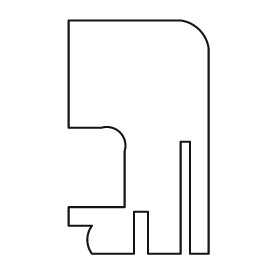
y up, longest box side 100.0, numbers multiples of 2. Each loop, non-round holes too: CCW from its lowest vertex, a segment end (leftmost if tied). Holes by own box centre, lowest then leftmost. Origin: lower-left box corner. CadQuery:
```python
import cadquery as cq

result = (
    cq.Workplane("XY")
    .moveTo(10.0, 0.0)
    .lineTo(28.0, 0.0)
    .lineTo(28.0, 18.0)
    .lineTo(34.0, 18.0)
    .lineTo(34.0, 0.0)
    .lineTo(48.0, 0.0)
    .lineTo(48.0, 48.0)
    .lineTo(52.0, 48.0)
    .lineTo(52.0, 0.0)
    .lineTo(60.0, 0.0)
    .lineTo(60.0, 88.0)
    .threePointArc((56.0, 96.0), (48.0, 100.0))
    .lineTo(0.0, 100.0)
    .lineTo(0.0, 54.0)
    .lineTo(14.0, 54.0)
    .threePointArc((22.0, 52.0), (24.0, 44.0))
    .lineTo(24.0, 20.0)
    .lineTo(0.0, 20.0)
    .lineTo(0.0, 12.0)
    .lineTo(10.0, 12.0)
    .threePointArc((8.0, 6.0), (10.0, 0.0))
    .close()
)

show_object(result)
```